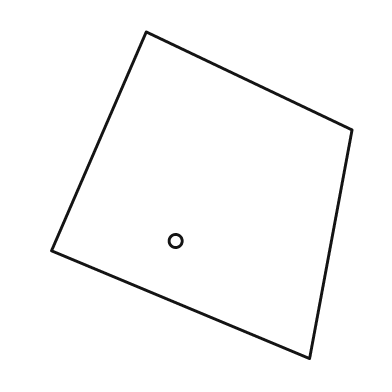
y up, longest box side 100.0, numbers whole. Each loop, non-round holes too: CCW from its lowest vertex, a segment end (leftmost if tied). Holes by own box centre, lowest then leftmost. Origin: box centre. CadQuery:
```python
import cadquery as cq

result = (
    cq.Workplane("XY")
    .moveTo(33.0, -50.0)
    .lineTo(46.0, 20.0)
    .lineTo(-17.0, 50.0)
    .lineTo(-46.0, -17.0)
    .close()
    .moveTo(-8.0, -14.0)
    .circle(2.0)
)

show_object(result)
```